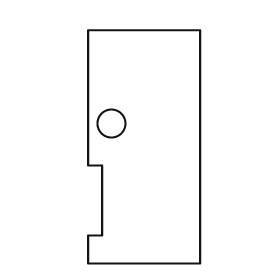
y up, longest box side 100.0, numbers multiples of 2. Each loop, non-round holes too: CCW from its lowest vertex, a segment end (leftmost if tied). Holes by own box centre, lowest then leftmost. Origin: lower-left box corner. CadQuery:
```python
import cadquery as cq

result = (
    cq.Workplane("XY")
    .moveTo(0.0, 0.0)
    .lineTo(48.0, 0.0)
    .lineTo(48.0, 100.0)
    .lineTo(0.0, 100.0)
    .lineTo(0.0, 42.0)
    .lineTo(6.0, 42.0)
    .lineTo(6.0, 12.0)
    .lineTo(0.0, 12.0)
    .close()
    .moveTo(10.0, 60.0)
    .circle(6.0)
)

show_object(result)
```